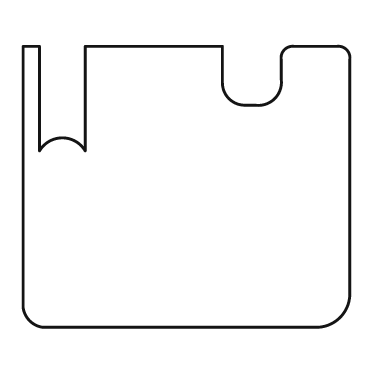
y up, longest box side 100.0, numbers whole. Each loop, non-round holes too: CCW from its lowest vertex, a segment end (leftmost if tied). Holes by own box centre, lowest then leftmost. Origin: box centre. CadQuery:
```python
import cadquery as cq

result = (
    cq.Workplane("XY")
    .moveTo(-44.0, -43.0)
    .lineTo(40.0, -43.0)
    .threePointArc((47.0, -40.0), (50.0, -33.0))
    .lineTo(50.0, 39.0)
    .threePointArc((49.0, 42.0), (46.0, 43.0))
    .lineTo(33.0, 43.0)
    .threePointArc((30.0, 42.0), (29.0, 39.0))
    .lineTo(29.0, 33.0)
    .threePointArc((27.0, 27.0), (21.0, 25.0))
    .lineTo(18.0, 25.0)
    .threePointArc((13.0, 27.0), (11.0, 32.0))
    .lineTo(11.0, 43.0)
    .lineTo(-31.0, 43.0)
    .lineTo(-31.0, 11.0)
    .threePointArc((-38.0, 15.0), (-45.0, 11.0))
    .lineTo(-45.0, 43.0)
    .lineTo(-50.0, 43.0)
    .lineTo(-50.0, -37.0)
    .threePointArc((-48.0, -41.0), (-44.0, -43.0))
    .close()
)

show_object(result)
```